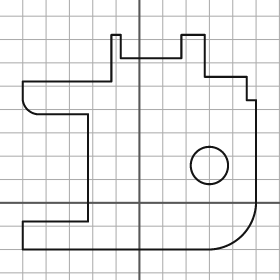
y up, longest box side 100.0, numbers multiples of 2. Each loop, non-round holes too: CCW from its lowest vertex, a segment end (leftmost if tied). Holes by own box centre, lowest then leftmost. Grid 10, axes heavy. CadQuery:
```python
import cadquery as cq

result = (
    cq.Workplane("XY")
    .moveTo(-50.0, -20.0)
    .lineTo(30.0, -20.0)
    .threePointArc((44.0, -14.0), (50.0, 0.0))
    .lineTo(50.0, 44.0)
    .lineTo(46.0, 44.0)
    .lineTo(46.0, 54.0)
    .lineTo(28.0, 54.0)
    .lineTo(28.0, 72.0)
    .lineTo(18.0, 72.0)
    .lineTo(18.0, 62.0)
    .lineTo(-8.0, 62.0)
    .lineTo(-8.0, 72.0)
    .lineTo(-12.0, 72.0)
    .lineTo(-12.0, 52.0)
    .lineTo(-50.0, 52.0)
    .lineTo(-50.0, 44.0)
    .threePointArc((-48.0, 40.0), (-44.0, 38.0))
    .lineTo(-22.0, 38.0)
    .lineTo(-22.0, -8.0)
    .lineTo(-50.0, -8.0)
    .close()
    .moveTo(30.0, 16.0)
    .circle(8.0)
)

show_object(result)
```